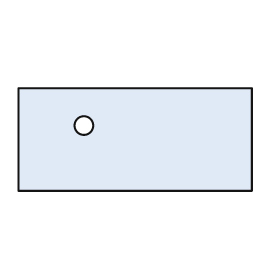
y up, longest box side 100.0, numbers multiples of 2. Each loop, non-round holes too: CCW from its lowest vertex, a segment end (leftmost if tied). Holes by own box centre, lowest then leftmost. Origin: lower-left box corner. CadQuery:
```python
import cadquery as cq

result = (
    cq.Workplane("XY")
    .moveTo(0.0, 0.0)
    .lineTo(100.0, 0.0)
    .lineTo(100.0, 44.0)
    .lineTo(0.0, 44.0)
    .close()
    .moveTo(28.0, 28.0)
    .circle(4.0)
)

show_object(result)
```